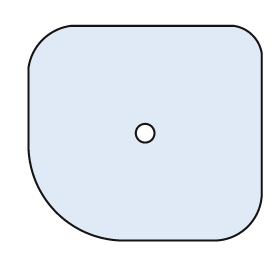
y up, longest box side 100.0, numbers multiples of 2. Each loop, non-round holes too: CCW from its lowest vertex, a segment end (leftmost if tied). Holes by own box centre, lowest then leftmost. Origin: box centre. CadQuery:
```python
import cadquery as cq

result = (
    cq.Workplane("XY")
    .moveTo(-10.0, -46.0)
    .lineTo(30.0, -46.0)
    .threePointArc((44.0, -40.0), (50.0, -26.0))
    .lineTo(50.0, 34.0)
    .threePointArc((46.0, 42.0), (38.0, 46.0))
    .lineTo(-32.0, 46.0)
    .threePointArc((-44.0, 40.0), (-50.0, 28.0))
    .lineTo(-50.0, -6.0)
    .threePointArc((-38.0, -34.0), (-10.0, -46.0))
    .close()
    .moveTo(0.0, 0.0)
    .circle(4.0)
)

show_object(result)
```